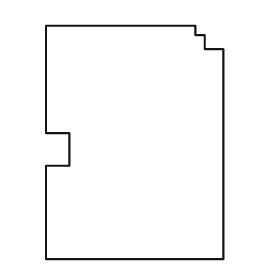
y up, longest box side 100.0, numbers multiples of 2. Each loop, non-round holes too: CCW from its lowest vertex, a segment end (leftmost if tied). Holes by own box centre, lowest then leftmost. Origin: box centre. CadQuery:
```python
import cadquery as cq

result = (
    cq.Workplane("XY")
    .moveTo(-38.0, -50.0)
    .lineTo(38.0, -50.0)
    .lineTo(38.0, 40.0)
    .lineTo(30.0, 40.0)
    .lineTo(30.0, 46.0)
    .lineTo(26.0, 46.0)
    .lineTo(26.0, 50.0)
    .lineTo(-38.0, 50.0)
    .lineTo(-38.0, 4.0)
    .lineTo(-28.0, 4.0)
    .lineTo(-28.0, -10.0)
    .lineTo(-38.0, -10.0)
    .close()
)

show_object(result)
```